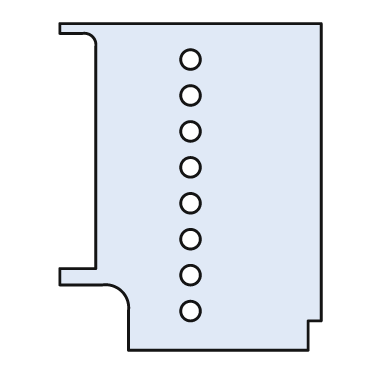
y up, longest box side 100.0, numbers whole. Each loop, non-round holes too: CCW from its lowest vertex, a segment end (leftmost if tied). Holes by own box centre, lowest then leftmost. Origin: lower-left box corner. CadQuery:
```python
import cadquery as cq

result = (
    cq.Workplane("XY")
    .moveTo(21.0, 0.0)
    .lineTo(76.0, 0.0)
    .lineTo(76.0, 9.0)
    .lineTo(80.0, 9.0)
    .lineTo(80.0, 100.0)
    .lineTo(0.0, 100.0)
    .lineTo(0.0, 97.0)
    .lineTo(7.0, 97.0)
    .threePointArc((10.0, 96.0), (11.0, 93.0))
    .lineTo(11.0, 25.0)
    .lineTo(0.0, 25.0)
    .lineTo(0.0, 20.0)
    .lineTo(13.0, 20.0)
    .threePointArc((19.0, 18.0), (21.0, 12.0))
    .close()
    .moveTo(40.0, 12.0)
    .circle(3.0)
    .moveTo(40.0, 23.0)
    .circle(3.0)
    .moveTo(40.0, 34.0)
    .circle(3.0)
    .moveTo(40.0, 45.0)
    .circle(3.0)
    .moveTo(40.0, 56.0)
    .circle(3.0)
    .moveTo(40.0, 67.0)
    .circle(3.0)
    .moveTo(40.0, 78.0)
    .circle(3.0)
    .moveTo(40.0, 89.0)
    .circle(3.0)
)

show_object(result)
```